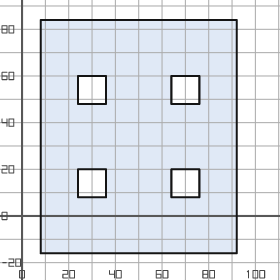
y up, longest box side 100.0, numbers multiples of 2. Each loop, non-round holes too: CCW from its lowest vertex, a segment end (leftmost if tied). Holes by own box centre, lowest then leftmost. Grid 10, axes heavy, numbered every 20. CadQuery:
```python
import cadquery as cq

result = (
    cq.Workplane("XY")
    .moveTo(8.0, -16.0)
    .lineTo(92.0, -16.0)
    .lineTo(92.0, 84.0)
    .lineTo(8.0, 84.0)
    .close()
    .moveTo(24.0, 8.0)
    .lineTo(36.0, 8.0)
    .lineTo(36.0, 20.0)
    .lineTo(24.0, 20.0)
    .close()
    .moveTo(64.0, 8.0)
    .lineTo(76.0, 8.0)
    .lineTo(76.0, 20.0)
    .lineTo(64.0, 20.0)
    .close()
    .moveTo(24.0, 48.0)
    .lineTo(36.0, 48.0)
    .lineTo(36.0, 60.0)
    .lineTo(24.0, 60.0)
    .close()
    .moveTo(64.0, 48.0)
    .lineTo(76.0, 48.0)
    .lineTo(76.0, 60.0)
    .lineTo(64.0, 60.0)
    .close()
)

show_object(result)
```